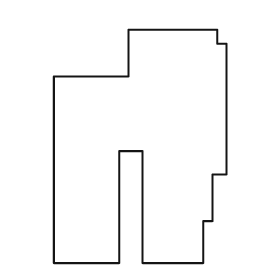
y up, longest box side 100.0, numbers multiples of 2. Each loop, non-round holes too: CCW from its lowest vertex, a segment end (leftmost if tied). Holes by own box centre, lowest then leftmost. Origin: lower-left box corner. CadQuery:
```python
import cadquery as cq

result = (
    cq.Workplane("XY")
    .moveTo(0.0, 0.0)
    .lineTo(28.0, 0.0)
    .lineTo(28.0, 48.0)
    .lineTo(38.0, 48.0)
    .lineTo(38.0, 0.0)
    .lineTo(64.0, 0.0)
    .lineTo(64.0, 18.0)
    .lineTo(68.0, 18.0)
    .lineTo(68.0, 38.0)
    .lineTo(74.0, 38.0)
    .lineTo(74.0, 94.0)
    .lineTo(70.0, 94.0)
    .lineTo(70.0, 100.0)
    .lineTo(32.0, 100.0)
    .lineTo(32.0, 80.0)
    .lineTo(0.0, 80.0)
    .close()
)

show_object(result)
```